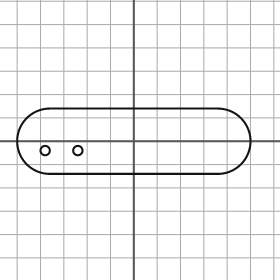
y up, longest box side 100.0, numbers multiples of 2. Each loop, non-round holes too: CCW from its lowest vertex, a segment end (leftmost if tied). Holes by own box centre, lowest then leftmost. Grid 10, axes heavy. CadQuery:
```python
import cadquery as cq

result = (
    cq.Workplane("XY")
    .moveTo(-36.0, -14.0)
    .lineTo(36.0, -14.0)
    .threePointArc((50.0, 0.0), (36.0, 14.0))
    .lineTo(-36.0, 14.0)
    .threePointArc((-50.0, 0.0), (-36.0, -14.0))
    .close()
    .moveTo(-38.0, -4.0)
    .circle(2.0)
    .moveTo(-24.0, -4.0)
    .circle(2.0)
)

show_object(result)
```